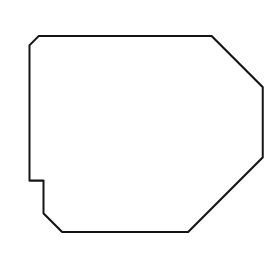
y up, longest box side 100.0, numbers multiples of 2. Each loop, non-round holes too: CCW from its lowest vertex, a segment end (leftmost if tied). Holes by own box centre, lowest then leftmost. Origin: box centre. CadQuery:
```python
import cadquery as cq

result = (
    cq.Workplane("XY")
    .moveTo(-36.0, -42.0)
    .lineTo(18.0, -42.0)
    .lineTo(50.0, -10.0)
    .lineTo(50.0, 20.0)
    .lineTo(28.0, 42.0)
    .lineTo(-46.0, 42.0)
    .lineTo(-50.0, 38.0)
    .lineTo(-50.0, -20.0)
    .lineTo(-44.0, -20.0)
    .lineTo(-44.0, -34.0)
    .close()
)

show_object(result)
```